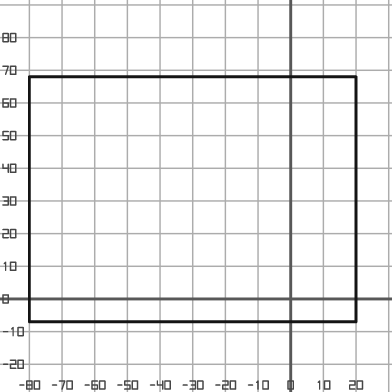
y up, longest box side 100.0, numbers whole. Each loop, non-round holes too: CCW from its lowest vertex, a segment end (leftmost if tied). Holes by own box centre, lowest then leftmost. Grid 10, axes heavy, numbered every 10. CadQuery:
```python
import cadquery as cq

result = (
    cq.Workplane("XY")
    .moveTo(-80.0, -7.0)
    .lineTo(20.0, -7.0)
    .lineTo(20.0, 68.0)
    .lineTo(-80.0, 68.0)
    .close()
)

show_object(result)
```